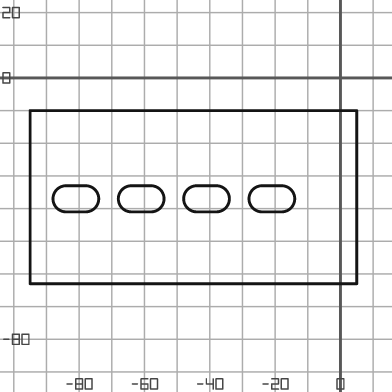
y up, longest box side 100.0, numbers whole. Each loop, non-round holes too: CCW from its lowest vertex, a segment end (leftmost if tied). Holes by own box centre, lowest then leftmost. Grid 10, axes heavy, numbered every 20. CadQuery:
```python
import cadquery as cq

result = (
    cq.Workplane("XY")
    .moveTo(-95.0, -63.0)
    .lineTo(5.0, -63.0)
    .lineTo(5.0, -10.0)
    .lineTo(-95.0, -10.0)
    .close()
    .moveTo(-84.0, -41.0)
    .lineTo(-78.0, -41.0)
    .threePointArc((-74.0, -37.0), (-78.0, -33.0))
    .lineTo(-84.0, -33.0)
    .threePointArc((-88.0, -37.0), (-84.0, -41.0))
    .close()
    .moveTo(-64.0, -41.0)
    .lineTo(-58.0, -41.0)
    .threePointArc((-54.0, -37.0), (-58.0, -33.0))
    .lineTo(-64.0, -33.0)
    .threePointArc((-68.0, -37.0), (-64.0, -41.0))
    .close()
    .moveTo(-44.0, -41.0)
    .lineTo(-38.0, -41.0)
    .threePointArc((-34.0, -37.0), (-38.0, -33.0))
    .lineTo(-44.0, -33.0)
    .threePointArc((-48.0, -37.0), (-44.0, -41.0))
    .close()
    .moveTo(-24.0, -41.0)
    .lineTo(-18.0, -41.0)
    .threePointArc((-14.0, -37.0), (-18.0, -33.0))
    .lineTo(-24.0, -33.0)
    .threePointArc((-28.0, -37.0), (-24.0, -41.0))
    .close()
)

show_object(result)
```